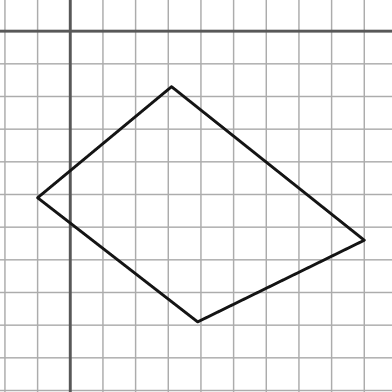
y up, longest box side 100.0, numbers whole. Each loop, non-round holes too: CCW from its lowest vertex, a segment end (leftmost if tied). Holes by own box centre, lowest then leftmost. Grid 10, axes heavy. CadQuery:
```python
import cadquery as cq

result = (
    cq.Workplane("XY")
    .moveTo(39.0, -89.0)
    .lineTo(90.0, -64.0)
    .lineTo(31.0, -17.0)
    .lineTo(-10.0, -51.0)
    .close()
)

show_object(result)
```